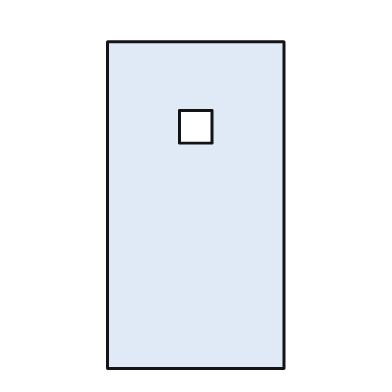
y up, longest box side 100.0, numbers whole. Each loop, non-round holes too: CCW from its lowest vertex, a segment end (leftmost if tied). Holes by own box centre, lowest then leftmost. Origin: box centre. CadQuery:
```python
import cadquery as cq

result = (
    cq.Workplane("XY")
    .moveTo(-27.0, -50.0)
    .lineTo(27.0, -50.0)
    .lineTo(27.0, 50.0)
    .lineTo(-27.0, 50.0)
    .close()
    .moveTo(-5.0, 19.0)
    .lineTo(5.0, 19.0)
    .lineTo(5.0, 29.0)
    .lineTo(-5.0, 29.0)
    .close()
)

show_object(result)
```